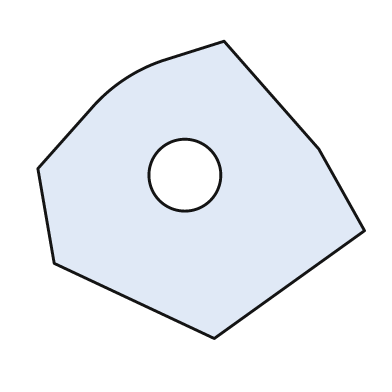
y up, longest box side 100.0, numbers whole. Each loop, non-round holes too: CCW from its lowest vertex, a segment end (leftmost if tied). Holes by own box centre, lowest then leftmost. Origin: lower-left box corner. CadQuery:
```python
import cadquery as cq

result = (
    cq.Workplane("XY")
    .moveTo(54.0, 0.0)
    .lineTo(100.0, 33.0)
    .lineTo(86.0, 58.0)
    .lineTo(57.0, 91.0)
    .lineTo(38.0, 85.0)
    .threePointArc((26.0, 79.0), (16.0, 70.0))
    .lineTo(0.0, 52.0)
    .lineTo(5.0, 23.0)
    .close()
    .moveTo(45.0, 50.0)
    .circle(11.0)
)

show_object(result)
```